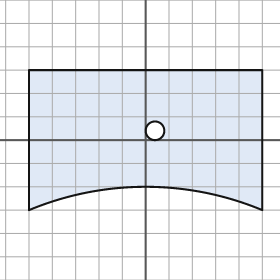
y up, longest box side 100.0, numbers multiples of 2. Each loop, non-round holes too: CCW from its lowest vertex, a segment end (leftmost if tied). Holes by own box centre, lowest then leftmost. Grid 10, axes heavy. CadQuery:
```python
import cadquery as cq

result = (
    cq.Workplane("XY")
    .moveTo(-50.0, -30.0)
    .threePointArc((0.0, -20.0), (50.0, -30.0))
    .lineTo(50.0, 30.0)
    .lineTo(-50.0, 30.0)
    .close()
    .moveTo(4.0, 4.0)
    .circle(4.0)
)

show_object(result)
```